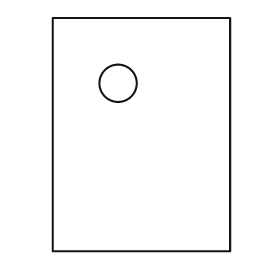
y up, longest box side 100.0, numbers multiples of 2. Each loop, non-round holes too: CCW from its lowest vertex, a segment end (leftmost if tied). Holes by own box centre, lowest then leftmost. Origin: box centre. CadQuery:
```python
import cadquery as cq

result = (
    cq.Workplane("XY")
    .moveTo(-38.0, -50.0)
    .lineTo(38.0, -50.0)
    .lineTo(38.0, 50.0)
    .lineTo(-38.0, 50.0)
    .close()
    .moveTo(-10.0, 22.0)
    .circle(8.0)
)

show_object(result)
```